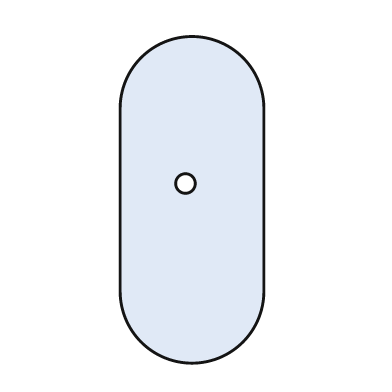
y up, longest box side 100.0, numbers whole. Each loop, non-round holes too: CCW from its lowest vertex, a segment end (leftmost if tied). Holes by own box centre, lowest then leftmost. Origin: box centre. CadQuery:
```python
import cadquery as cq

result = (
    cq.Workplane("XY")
    .moveTo(-22.0, -28.0)
    .threePointArc((0.0, -50.0), (22.0, -28.0))
    .lineTo(22.0, 28.0)
    .threePointArc((0.0, 50.0), (-22.0, 28.0))
    .close()
    .moveTo(-2.0, 5.0)
    .circle(3.0)
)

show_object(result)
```